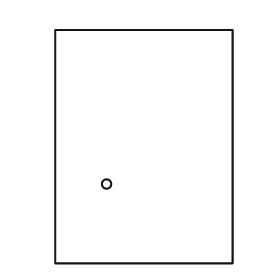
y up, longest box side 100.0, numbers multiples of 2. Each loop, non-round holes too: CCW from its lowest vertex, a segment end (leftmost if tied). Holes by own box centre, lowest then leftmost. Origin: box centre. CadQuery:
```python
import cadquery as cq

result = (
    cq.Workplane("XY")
    .moveTo(-38.0, -50.0)
    .lineTo(38.0, -50.0)
    .lineTo(38.0, 50.0)
    .lineTo(-38.0, 50.0)
    .close()
    .moveTo(-16.0, -16.0)
    .circle(2.0)
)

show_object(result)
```